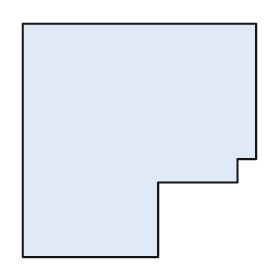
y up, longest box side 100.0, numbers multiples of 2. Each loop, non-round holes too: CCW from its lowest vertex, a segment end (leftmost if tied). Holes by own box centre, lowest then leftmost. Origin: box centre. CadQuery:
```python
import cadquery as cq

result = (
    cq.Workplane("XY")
    .moveTo(-50.0, -50.0)
    .lineTo(8.0, -50.0)
    .lineTo(8.0, -18.0)
    .lineTo(42.0, -18.0)
    .lineTo(42.0, -8.0)
    .lineTo(50.0, -8.0)
    .lineTo(50.0, 50.0)
    .lineTo(-50.0, 50.0)
    .close()
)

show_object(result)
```